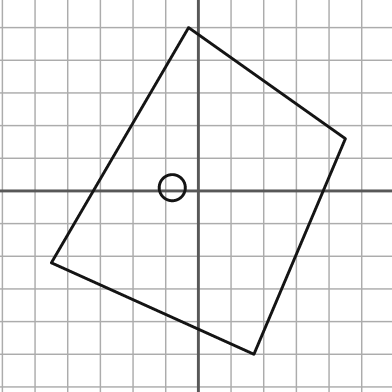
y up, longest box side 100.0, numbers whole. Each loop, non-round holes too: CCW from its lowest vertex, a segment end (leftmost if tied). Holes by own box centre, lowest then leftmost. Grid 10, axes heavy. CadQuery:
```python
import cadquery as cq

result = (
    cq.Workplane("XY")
    .moveTo(17.0, -50.0)
    .lineTo(45.0, 16.0)
    .lineTo(-3.0, 50.0)
    .lineTo(-45.0, -22.0)
    .close()
    .moveTo(-8.0, 1.0)
    .circle(4.0)
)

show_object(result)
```